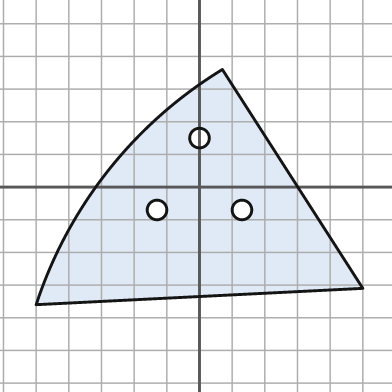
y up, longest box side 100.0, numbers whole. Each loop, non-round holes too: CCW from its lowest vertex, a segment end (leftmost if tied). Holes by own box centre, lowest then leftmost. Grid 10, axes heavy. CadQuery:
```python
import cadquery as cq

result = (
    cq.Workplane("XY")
    .moveTo(-50.0, -36.0)
    .lineTo(50.0, -31.0)
    .lineTo(7.0, 36.0)
    .threePointArc((-28.0, 5.0), (-50.0, -36.0))
    .close()
    .moveTo(-13.0, -7.0)
    .circle(3.0)
    .moveTo(13.0, -7.0)
    .circle(3.0)
    .moveTo(0.0, 15.0)
    .circle(3.0)
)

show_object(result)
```